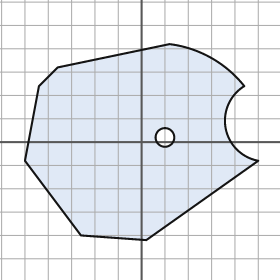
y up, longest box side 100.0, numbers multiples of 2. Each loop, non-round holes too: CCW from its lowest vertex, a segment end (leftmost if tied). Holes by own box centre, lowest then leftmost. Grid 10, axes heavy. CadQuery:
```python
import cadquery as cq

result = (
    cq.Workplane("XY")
    .moveTo(2.0, -42.0)
    .lineTo(50.0, -8.0)
    .threePointArc((36.0, 6.0), (44.0, 24.0))
    .threePointArc((30.0, 36.0), (12.0, 42.0))
    .lineTo(-36.0, 32.0)
    .lineTo(-44.0, 24.0)
    .lineTo(-50.0, -8.0)
    .lineTo(-26.0, -40.0)
    .close()
    .moveTo(10.0, 2.0)
    .circle(4.0)
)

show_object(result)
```